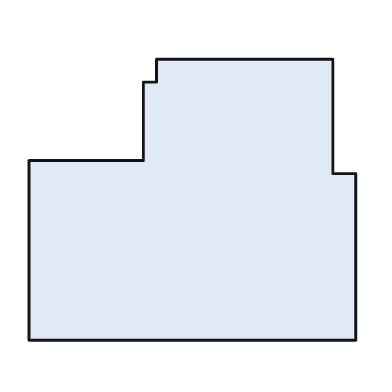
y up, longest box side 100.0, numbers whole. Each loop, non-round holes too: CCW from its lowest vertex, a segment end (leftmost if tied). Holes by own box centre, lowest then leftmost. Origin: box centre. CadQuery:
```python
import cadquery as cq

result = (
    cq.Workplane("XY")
    .moveTo(-50.0, -43.0)
    .lineTo(50.0, -43.0)
    .lineTo(50.0, 8.0)
    .lineTo(43.0, 8.0)
    .lineTo(43.0, 43.0)
    .lineTo(-11.0, 43.0)
    .lineTo(-11.0, 36.0)
    .lineTo(-15.0, 36.0)
    .lineTo(-15.0, 12.0)
    .lineTo(-50.0, 12.0)
    .close()
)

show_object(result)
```